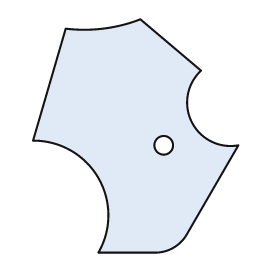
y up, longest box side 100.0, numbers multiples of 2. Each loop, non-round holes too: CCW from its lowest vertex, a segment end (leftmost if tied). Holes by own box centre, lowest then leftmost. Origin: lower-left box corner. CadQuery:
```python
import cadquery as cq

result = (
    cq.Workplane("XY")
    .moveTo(28.0, 0.0)
    .lineTo(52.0, 0.0)
    .threePointArc((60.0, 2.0), (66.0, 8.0))
    .lineTo(88.0, 46.0)
    .threePointArc((68.0, 56.0), (72.0, 78.0))
    .lineTo(46.0, 100.0)
    .threePointArc((30.0, 96.0), (14.0, 96.0))
    .lineTo(0.0, 48.0)
    .threePointArc((28.0, 32.0), (28.0, 0.0))
    .close()
    .moveTo(56.0, 46.0)
    .circle(4.0)
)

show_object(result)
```